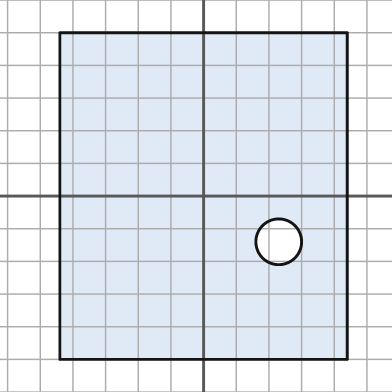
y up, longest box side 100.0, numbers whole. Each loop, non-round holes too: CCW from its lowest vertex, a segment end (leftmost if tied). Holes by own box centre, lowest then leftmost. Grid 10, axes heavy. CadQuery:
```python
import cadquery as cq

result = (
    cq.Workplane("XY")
    .moveTo(-44.0, -50.0)
    .lineTo(44.0, -50.0)
    .lineTo(44.0, 50.0)
    .lineTo(-44.0, 50.0)
    .close()
    .moveTo(23.0, -14.0)
    .circle(7.0)
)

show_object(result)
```